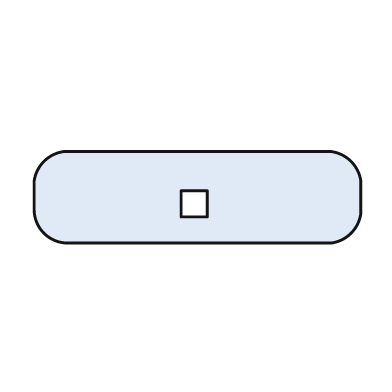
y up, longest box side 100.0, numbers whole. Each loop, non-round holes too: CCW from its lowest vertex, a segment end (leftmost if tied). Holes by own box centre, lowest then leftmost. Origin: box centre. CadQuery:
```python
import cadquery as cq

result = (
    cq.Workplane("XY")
    .moveTo(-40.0, -14.0)
    .lineTo(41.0, -14.0)
    .threePointArc((47.0, -11.0), (50.0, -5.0))
    .lineTo(50.0, 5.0)
    .threePointArc((47.0, 11.0), (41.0, 14.0))
    .lineTo(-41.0, 14.0)
    .threePointArc((-47.0, 11.0), (-50.0, 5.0))
    .lineTo(-50.0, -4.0)
    .threePointArc((-47.0, -11.0), (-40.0, -14.0))
    .close()
    .moveTo(-5.0, -6.0)
    .lineTo(3.0, -6.0)
    .lineTo(3.0, 2.0)
    .lineTo(-5.0, 2.0)
    .close()
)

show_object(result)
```